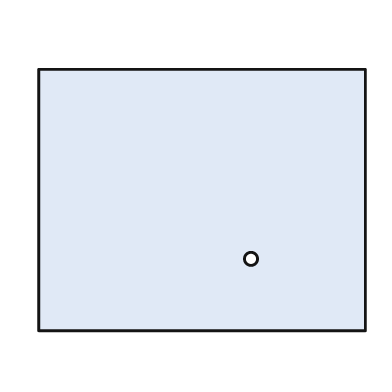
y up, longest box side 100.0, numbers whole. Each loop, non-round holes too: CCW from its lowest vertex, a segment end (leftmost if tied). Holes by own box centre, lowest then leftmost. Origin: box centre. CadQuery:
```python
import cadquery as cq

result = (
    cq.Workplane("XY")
    .moveTo(-50.0, -40.0)
    .lineTo(50.0, -40.0)
    .lineTo(50.0, 40.0)
    .lineTo(-50.0, 40.0)
    .close()
    .moveTo(15.0, -18.0)
    .circle(2.0)
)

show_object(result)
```